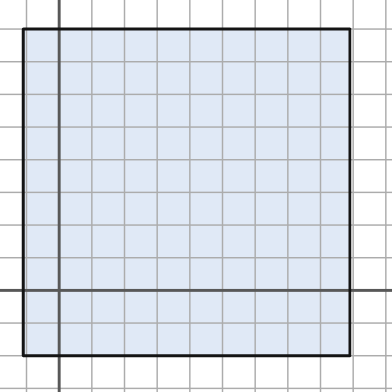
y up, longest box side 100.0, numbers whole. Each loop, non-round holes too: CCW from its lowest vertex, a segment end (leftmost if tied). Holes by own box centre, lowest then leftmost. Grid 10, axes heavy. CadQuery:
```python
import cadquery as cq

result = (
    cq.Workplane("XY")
    .moveTo(-11.0, -20.0)
    .lineTo(89.0, -20.0)
    .lineTo(89.0, 80.0)
    .lineTo(-11.0, 80.0)
    .close()
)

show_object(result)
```